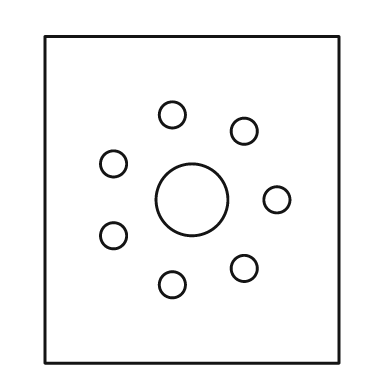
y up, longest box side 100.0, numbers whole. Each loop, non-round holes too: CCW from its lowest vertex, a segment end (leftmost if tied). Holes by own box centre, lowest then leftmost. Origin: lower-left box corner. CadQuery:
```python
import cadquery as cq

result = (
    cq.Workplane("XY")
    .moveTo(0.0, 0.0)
    .lineTo(90.0, 0.0)
    .lineTo(90.0, 100.0)
    .lineTo(0.0, 100.0)
    .close()
    .moveTo(39.0, 24.0)
    .circle(4.0)
    .moveTo(61.0, 29.0)
    .circle(4.0)
    .moveTo(21.0, 39.0)
    .circle(4.0)
    .moveTo(45.0, 50.0)
    .circle(11.0)
    .moveTo(71.0, 50.0)
    .circle(4.0)
    .moveTo(21.0, 61.0)
    .circle(4.0)
    .moveTo(61.0, 71.0)
    .circle(4.0)
    .moveTo(39.0, 76.0)
    .circle(4.0)
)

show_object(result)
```